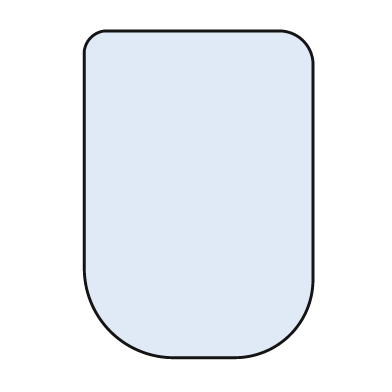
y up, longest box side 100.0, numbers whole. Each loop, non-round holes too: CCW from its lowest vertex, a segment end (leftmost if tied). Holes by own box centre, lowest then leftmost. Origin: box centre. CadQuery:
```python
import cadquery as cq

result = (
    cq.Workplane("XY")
    .moveTo(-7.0, -50.0)
    .lineTo(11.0, -50.0)
    .threePointArc((28.0, -43.0), (35.0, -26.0))
    .lineTo(35.0, 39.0)
    .threePointArc((32.0, 47.0), (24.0, 50.0))
    .lineTo(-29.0, 50.0)
    .threePointArc((-33.0, 48.0), (-35.0, 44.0))
    .lineTo(-35.0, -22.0)
    .threePointArc((-27.0, -42.0), (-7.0, -50.0))
    .close()
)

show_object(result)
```